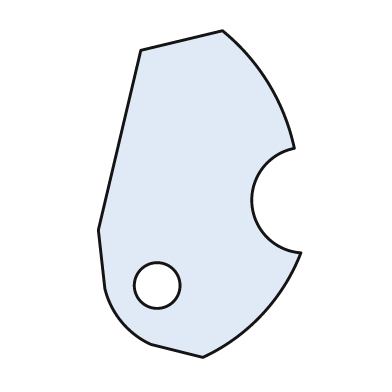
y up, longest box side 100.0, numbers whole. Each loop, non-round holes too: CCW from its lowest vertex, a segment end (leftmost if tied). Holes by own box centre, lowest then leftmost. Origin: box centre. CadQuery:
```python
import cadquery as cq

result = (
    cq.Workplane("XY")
    .moveTo(1.0, -50.0)
    .threePointArc((19.0, -37.0), (31.0, -18.0))
    .threePointArc((16.0, -3.0), (29.0, 14.0))
    .threePointArc((21.0, 34.0), (7.0, 50.0))
    .lineTo(-18.0, 44.0)
    .lineTo(-31.0, -11.0)
    .lineTo(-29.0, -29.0)
    .threePointArc((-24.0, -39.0), (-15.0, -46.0))
    .close()
    .moveTo(-13.0, -28.0)
    .circle(7.0)
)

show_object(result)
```